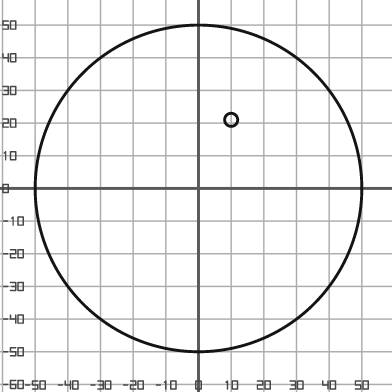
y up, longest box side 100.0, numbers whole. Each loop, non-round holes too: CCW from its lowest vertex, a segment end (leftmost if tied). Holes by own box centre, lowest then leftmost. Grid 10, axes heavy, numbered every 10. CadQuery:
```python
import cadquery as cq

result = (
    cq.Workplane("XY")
    .moveTo(0.0, 0.0)
    .circle(50.0)
    .moveTo(10.0, 21.0)
    .circle(2.0)
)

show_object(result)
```